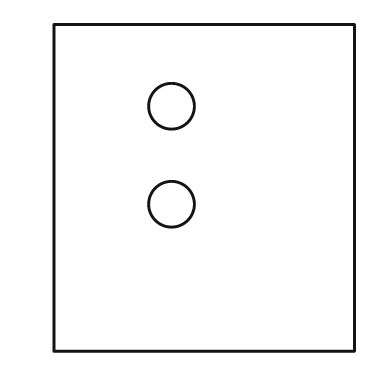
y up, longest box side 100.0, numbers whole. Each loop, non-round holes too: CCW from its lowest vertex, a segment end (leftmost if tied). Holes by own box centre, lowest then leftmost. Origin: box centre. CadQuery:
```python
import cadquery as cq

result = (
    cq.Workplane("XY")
    .moveTo(-46.0, -50.0)
    .lineTo(46.0, -50.0)
    .lineTo(46.0, 50.0)
    .lineTo(-46.0, 50.0)
    .close()
    .moveTo(-10.0, -5.0)
    .circle(7.0)
    .moveTo(-10.0, 25.0)
    .circle(7.0)
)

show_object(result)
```